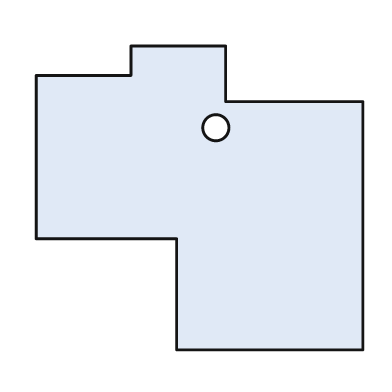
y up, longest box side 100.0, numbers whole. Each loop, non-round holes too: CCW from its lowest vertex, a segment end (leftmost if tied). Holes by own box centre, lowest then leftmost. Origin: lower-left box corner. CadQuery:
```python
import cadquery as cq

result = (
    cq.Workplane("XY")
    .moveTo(43.0, 0.0)
    .lineTo(100.0, 0.0)
    .lineTo(100.0, 76.0)
    .lineTo(58.0, 76.0)
    .lineTo(58.0, 93.0)
    .lineTo(29.0, 93.0)
    .lineTo(29.0, 84.0)
    .lineTo(0.0, 84.0)
    .lineTo(0.0, 34.0)
    .lineTo(43.0, 34.0)
    .close()
    .moveTo(55.0, 68.0)
    .circle(4.0)
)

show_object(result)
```